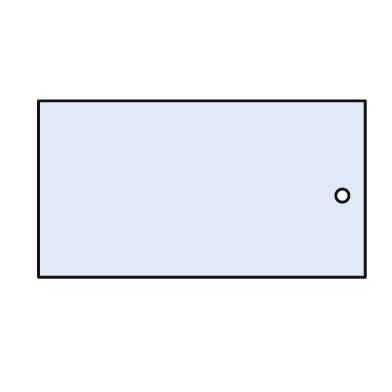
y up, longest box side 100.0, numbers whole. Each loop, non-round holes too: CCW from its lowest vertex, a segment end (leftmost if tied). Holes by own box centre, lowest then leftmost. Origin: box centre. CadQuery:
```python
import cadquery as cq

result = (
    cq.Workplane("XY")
    .moveTo(-50.0, -27.0)
    .lineTo(50.0, -27.0)
    .lineTo(50.0, 27.0)
    .lineTo(-50.0, 27.0)
    .close()
    .moveTo(43.0, -2.0)
    .circle(2.0)
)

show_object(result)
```